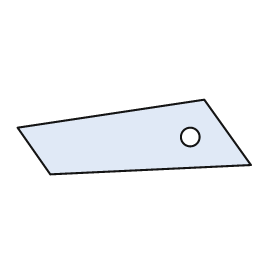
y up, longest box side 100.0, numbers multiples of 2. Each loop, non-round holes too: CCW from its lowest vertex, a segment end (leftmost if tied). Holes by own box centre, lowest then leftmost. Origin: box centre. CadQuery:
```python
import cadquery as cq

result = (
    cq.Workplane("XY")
    .moveTo(-36.0, -16.0)
    .lineTo(50.0, -12.0)
    .lineTo(30.0, 16.0)
    .lineTo(-50.0, 4.0)
    .close()
    .moveTo(24.0, 0.0)
    .circle(4.0)
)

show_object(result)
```